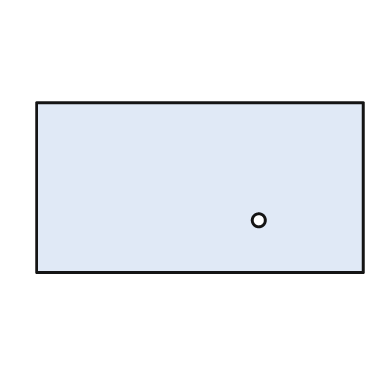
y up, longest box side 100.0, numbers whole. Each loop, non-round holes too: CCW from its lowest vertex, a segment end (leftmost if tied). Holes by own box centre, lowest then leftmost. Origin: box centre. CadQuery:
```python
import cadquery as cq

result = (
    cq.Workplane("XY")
    .moveTo(-50.0, -26.0)
    .lineTo(50.0, -26.0)
    .lineTo(50.0, 26.0)
    .lineTo(-50.0, 26.0)
    .close()
    .moveTo(18.0, -10.0)
    .circle(2.0)
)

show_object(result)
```